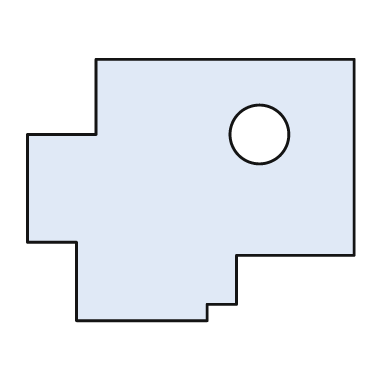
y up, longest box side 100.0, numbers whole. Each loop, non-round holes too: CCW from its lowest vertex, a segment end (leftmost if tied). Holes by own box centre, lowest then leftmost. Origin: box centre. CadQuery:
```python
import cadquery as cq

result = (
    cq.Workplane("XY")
    .moveTo(-35.0, -40.0)
    .lineTo(5.0, -40.0)
    .lineTo(5.0, -35.0)
    .lineTo(14.0, -35.0)
    .lineTo(14.0, -20.0)
    .lineTo(50.0, -20.0)
    .lineTo(50.0, 40.0)
    .lineTo(-29.0, 40.0)
    .lineTo(-29.0, 17.0)
    .lineTo(-50.0, 17.0)
    .lineTo(-50.0, -16.0)
    .lineTo(-35.0, -16.0)
    .close()
    .moveTo(21.0, 17.0)
    .circle(9.0)
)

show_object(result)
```